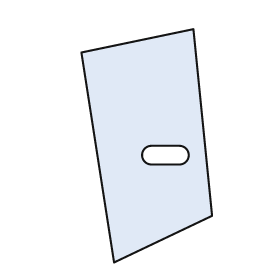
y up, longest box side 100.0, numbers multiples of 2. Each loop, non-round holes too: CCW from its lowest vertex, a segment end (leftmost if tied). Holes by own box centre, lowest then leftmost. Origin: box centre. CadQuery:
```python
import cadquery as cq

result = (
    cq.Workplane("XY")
    .moveTo(-14.0, -50.0)
    .lineTo(28.0, -30.0)
    .lineTo(20.0, 50.0)
    .lineTo(-28.0, 40.0)
    .close()
    .moveTo(2.0, -8.0)
    .lineTo(14.0, -8.0)
    .threePointArc((18.0, -4.0), (14.0, 0.0))
    .lineTo(2.0, 0.0)
    .threePointArc((-2.0, -4.0), (2.0, -8.0))
    .close()
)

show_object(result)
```